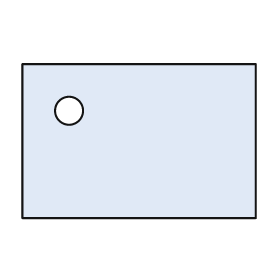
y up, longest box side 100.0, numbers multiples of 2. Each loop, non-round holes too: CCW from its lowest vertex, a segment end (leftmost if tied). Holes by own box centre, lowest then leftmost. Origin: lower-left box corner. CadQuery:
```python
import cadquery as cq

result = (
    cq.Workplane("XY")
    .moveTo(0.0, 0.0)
    .lineTo(100.0, 0.0)
    .lineTo(100.0, 66.0)
    .lineTo(0.0, 66.0)
    .close()
    .moveTo(20.0, 46.0)
    .circle(6.0)
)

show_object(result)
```